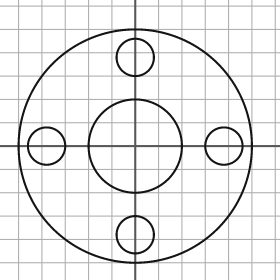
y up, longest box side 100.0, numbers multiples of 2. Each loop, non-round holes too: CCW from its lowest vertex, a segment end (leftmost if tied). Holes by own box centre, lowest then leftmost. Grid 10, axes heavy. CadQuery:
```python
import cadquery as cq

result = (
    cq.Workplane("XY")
    .moveTo(0.0, 0.0)
    .circle(50.0)
    .moveTo(0.0, -38.0)
    .circle(8.0)
    .moveTo(-38.0, 0.0)
    .circle(8.0)
    .moveTo(0.0, 0.0)
    .circle(20.0)
    .moveTo(38.0, 0.0)
    .circle(8.0)
    .moveTo(0.0, 38.0)
    .circle(8.0)
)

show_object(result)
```